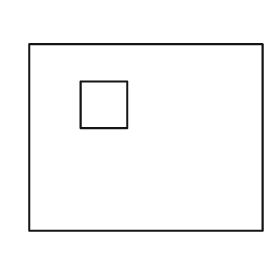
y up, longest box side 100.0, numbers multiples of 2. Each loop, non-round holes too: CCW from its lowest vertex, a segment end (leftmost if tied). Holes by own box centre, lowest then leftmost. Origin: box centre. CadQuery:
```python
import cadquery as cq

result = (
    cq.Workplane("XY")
    .moveTo(-50.0, -40.0)
    .lineTo(50.0, -40.0)
    .lineTo(50.0, 40.0)
    .lineTo(-50.0, 40.0)
    .close()
    .moveTo(-28.0, 4.0)
    .lineTo(-8.0, 4.0)
    .lineTo(-8.0, 24.0)
    .lineTo(-28.0, 24.0)
    .close()
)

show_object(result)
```